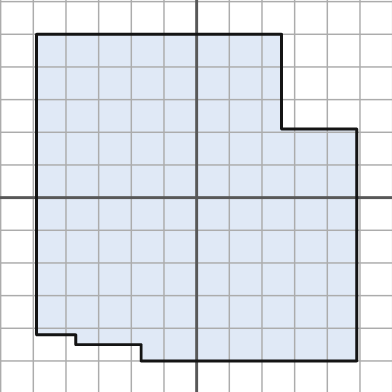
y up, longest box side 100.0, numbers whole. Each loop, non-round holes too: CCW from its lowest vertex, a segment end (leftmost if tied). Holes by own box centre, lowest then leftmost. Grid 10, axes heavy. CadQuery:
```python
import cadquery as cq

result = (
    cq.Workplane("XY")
    .moveTo(-17.0, -50.0)
    .lineTo(49.0, -50.0)
    .lineTo(49.0, 21.0)
    .lineTo(26.0, 21.0)
    .lineTo(26.0, 50.0)
    .lineTo(-49.0, 50.0)
    .lineTo(-49.0, -42.0)
    .lineTo(-37.0, -42.0)
    .lineTo(-37.0, -45.0)
    .lineTo(-17.0, -45.0)
    .close()
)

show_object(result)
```